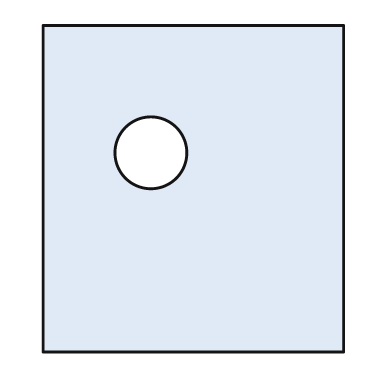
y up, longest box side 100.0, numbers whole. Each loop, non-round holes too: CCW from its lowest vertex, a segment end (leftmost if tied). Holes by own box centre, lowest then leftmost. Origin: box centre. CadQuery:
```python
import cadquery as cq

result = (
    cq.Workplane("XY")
    .moveTo(-46.0, -50.0)
    .lineTo(46.0, -50.0)
    .lineTo(46.0, 50.0)
    .lineTo(-46.0, 50.0)
    .close()
    .moveTo(-13.0, 11.0)
    .circle(11.0)
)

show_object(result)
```